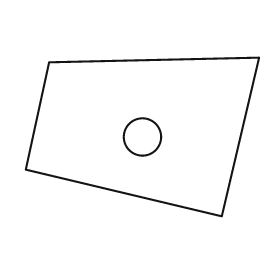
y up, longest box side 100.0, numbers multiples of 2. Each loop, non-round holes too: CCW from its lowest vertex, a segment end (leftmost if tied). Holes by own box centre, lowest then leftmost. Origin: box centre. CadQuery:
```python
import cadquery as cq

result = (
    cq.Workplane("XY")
    .moveTo(34.0, -34.0)
    .lineTo(50.0, 34.0)
    .lineTo(-40.0, 32.0)
    .lineTo(-50.0, -14.0)
    .close()
    .moveTo(0.0, 0.0)
    .circle(8.0)
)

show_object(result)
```